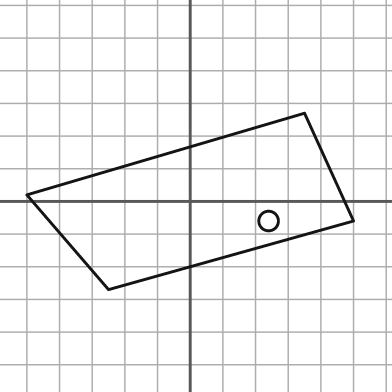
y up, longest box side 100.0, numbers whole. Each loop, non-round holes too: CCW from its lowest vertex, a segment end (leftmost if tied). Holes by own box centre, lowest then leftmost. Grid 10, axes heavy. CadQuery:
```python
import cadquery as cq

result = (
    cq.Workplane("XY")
    .moveTo(-25.0, -27.0)
    .lineTo(50.0, -6.0)
    .lineTo(35.0, 27.0)
    .lineTo(-50.0, 2.0)
    .close()
    .moveTo(24.0, -6.0)
    .circle(3.0)
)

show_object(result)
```